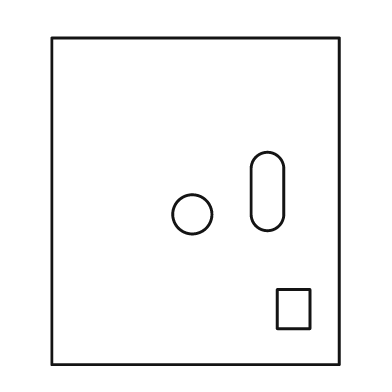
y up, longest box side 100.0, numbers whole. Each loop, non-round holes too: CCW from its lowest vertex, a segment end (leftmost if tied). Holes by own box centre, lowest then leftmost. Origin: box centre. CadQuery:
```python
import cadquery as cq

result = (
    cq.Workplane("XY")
    .moveTo(-44.0, -50.0)
    .lineTo(44.0, -50.0)
    .lineTo(44.0, 50.0)
    .lineTo(-44.0, 50.0)
    .close()
    .moveTo(25.0, -39.0)
    .lineTo(35.0, -39.0)
    .lineTo(35.0, -27.0)
    .lineTo(25.0, -27.0)
    .close()
    .moveTo(-1.0, -4.0)
    .circle(6.0)
    .moveTo(17.0, -4.0)
    .threePointArc((22.0, -9.0), (27.0, -4.0))
    .lineTo(27.0, 10.0)
    .threePointArc((22.0, 15.0), (17.0, 10.0))
    .close()
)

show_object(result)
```